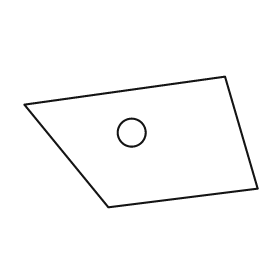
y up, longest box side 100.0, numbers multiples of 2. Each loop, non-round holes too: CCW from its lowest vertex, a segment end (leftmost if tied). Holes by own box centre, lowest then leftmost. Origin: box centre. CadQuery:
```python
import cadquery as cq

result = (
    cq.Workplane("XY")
    .moveTo(-14.0, -28.0)
    .lineTo(50.0, -20.0)
    .lineTo(36.0, 28.0)
    .lineTo(-50.0, 16.0)
    .close()
    .moveTo(-4.0, 4.0)
    .circle(6.0)
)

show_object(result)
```